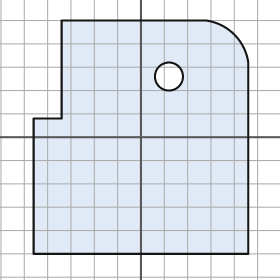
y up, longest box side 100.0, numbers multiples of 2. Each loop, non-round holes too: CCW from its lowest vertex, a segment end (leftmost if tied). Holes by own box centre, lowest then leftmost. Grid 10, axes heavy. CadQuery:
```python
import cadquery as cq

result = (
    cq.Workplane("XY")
    .moveTo(-46.0, -50.0)
    .lineTo(46.0, -50.0)
    .lineTo(46.0, 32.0)
    .threePointArc((40.0, 44.0), (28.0, 50.0))
    .lineTo(-34.0, 50.0)
    .lineTo(-34.0, 8.0)
    .lineTo(-46.0, 8.0)
    .close()
    .moveTo(12.0, 26.0)
    .circle(6.0)
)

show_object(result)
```